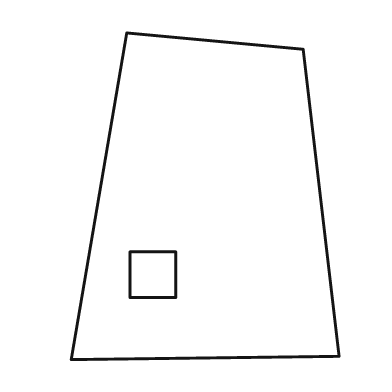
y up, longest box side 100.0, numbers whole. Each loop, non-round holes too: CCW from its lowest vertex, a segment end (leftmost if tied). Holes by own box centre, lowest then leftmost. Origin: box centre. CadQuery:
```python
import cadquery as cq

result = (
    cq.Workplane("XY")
    .moveTo(-41.0, -50.0)
    .lineTo(41.0, -49.0)
    .lineTo(30.0, 45.0)
    .lineTo(-24.0, 50.0)
    .close()
    .moveTo(-23.0, -31.0)
    .lineTo(-9.0, -31.0)
    .lineTo(-9.0, -17.0)
    .lineTo(-23.0, -17.0)
    .close()
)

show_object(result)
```